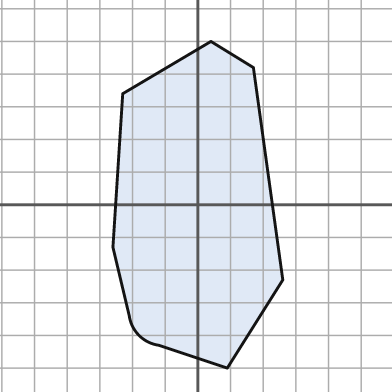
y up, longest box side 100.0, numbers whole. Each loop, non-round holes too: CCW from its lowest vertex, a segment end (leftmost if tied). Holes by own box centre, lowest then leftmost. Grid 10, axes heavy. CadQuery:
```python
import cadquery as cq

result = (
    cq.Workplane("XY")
    .moveTo(9.0, -50.0)
    .lineTo(26.0, -23.0)
    .lineTo(17.0, 42.0)
    .lineTo(4.0, 50.0)
    .lineTo(-23.0, 34.0)
    .lineTo(-26.0, -13.0)
    .lineTo(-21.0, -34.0)
    .threePointArc((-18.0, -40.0), (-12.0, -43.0))
    .close()
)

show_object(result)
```